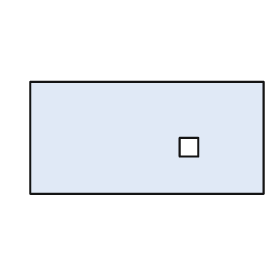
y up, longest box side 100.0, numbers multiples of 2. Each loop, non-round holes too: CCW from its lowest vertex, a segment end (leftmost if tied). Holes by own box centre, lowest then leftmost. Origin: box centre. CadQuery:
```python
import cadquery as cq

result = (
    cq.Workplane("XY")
    .moveTo(-50.0, -24.0)
    .lineTo(50.0, -24.0)
    .lineTo(50.0, 24.0)
    .lineTo(-50.0, 24.0)
    .close()
    .moveTo(14.0, -8.0)
    .lineTo(22.0, -8.0)
    .lineTo(22.0, 0.0)
    .lineTo(14.0, 0.0)
    .close()
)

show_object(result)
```